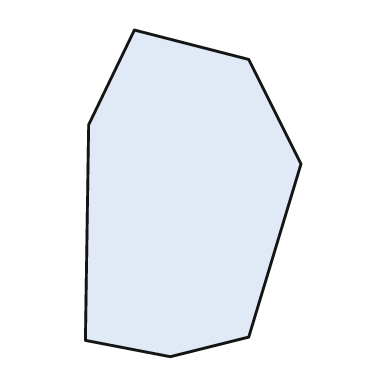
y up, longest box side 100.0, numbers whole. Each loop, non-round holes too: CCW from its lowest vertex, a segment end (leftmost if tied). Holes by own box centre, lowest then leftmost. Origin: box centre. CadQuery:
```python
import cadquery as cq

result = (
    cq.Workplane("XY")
    .moveTo(-7.0, -50.0)
    .lineTo(17.0, -44.0)
    .lineTo(33.0, 9.0)
    .lineTo(17.0, 41.0)
    .lineTo(-18.0, 50.0)
    .lineTo(-32.0, 21.0)
    .lineTo(-33.0, -45.0)
    .close()
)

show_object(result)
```